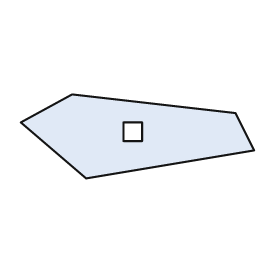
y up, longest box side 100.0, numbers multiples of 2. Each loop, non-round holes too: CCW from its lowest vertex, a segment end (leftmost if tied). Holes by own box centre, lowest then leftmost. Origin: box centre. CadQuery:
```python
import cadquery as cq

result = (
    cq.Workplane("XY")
    .moveTo(-22.0, -18.0)
    .lineTo(50.0, -6.0)
    .lineTo(42.0, 10.0)
    .lineTo(-28.0, 18.0)
    .lineTo(-50.0, 6.0)
    .close()
    .moveTo(-6.0, -2.0)
    .lineTo(2.0, -2.0)
    .lineTo(2.0, 6.0)
    .lineTo(-6.0, 6.0)
    .close()
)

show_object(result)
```